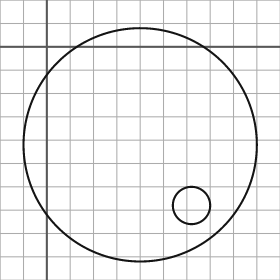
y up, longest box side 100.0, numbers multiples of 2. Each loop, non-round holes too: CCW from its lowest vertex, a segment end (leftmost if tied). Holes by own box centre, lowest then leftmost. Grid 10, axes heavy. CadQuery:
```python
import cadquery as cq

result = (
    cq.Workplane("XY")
    .moveTo(40.0, -42.0)
    .circle(50.0)
    .moveTo(62.0, -68.0)
    .circle(8.0)
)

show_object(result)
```